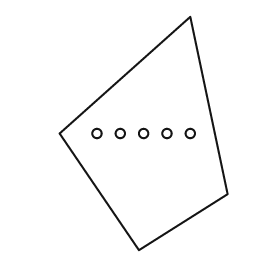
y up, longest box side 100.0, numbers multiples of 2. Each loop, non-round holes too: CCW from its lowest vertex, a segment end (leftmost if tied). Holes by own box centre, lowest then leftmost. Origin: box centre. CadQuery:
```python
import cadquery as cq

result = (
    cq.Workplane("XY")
    .moveTo(-2.0, -50.0)
    .lineTo(36.0, -26.0)
    .lineTo(20.0, 50.0)
    .lineTo(-36.0, 0.0)
    .close()
    .moveTo(-20.0, 0.0)
    .circle(2.0)
    .moveTo(-10.0, 0.0)
    .circle(2.0)
    .moveTo(0.0, 0.0)
    .circle(2.0)
    .moveTo(10.0, 0.0)
    .circle(2.0)
    .moveTo(20.0, 0.0)
    .circle(2.0)
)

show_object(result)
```